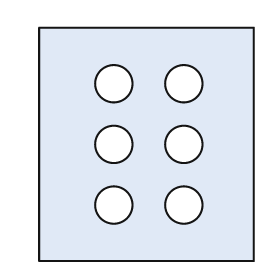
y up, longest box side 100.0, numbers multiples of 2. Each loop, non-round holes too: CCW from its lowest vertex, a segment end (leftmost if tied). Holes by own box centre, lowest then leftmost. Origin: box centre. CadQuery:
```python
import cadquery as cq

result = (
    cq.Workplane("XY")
    .moveTo(-46.0, -50.0)
    .lineTo(46.0, -50.0)
    .lineTo(46.0, 50.0)
    .lineTo(-46.0, 50.0)
    .close()
    .moveTo(-14.0, -26.0)
    .circle(8.0)
    .moveTo(16.0, -26.0)
    .circle(8.0)
    .moveTo(-14.0, 0.0)
    .circle(8.0)
    .moveTo(16.0, 0.0)
    .circle(8.0)
    .moveTo(-14.0, 26.0)
    .circle(8.0)
    .moveTo(16.0, 26.0)
    .circle(8.0)
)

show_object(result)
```